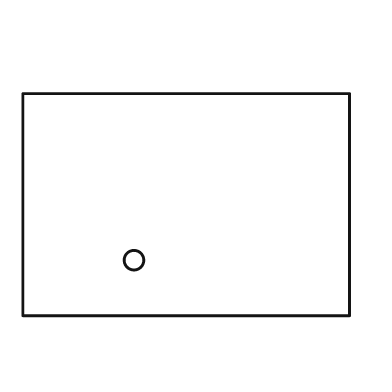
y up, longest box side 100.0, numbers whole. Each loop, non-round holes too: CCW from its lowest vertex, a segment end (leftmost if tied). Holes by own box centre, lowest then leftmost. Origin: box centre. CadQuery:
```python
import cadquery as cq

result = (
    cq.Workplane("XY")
    .moveTo(-50.0, -34.0)
    .lineTo(50.0, -34.0)
    .lineTo(50.0, 34.0)
    .lineTo(-50.0, 34.0)
    .close()
    .moveTo(-16.0, -17.0)
    .circle(3.0)
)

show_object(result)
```